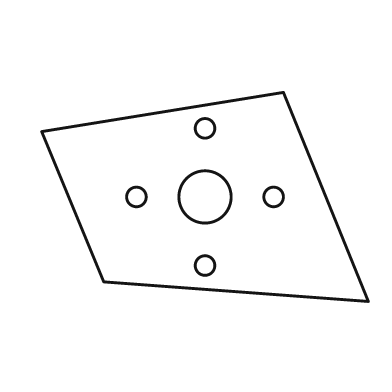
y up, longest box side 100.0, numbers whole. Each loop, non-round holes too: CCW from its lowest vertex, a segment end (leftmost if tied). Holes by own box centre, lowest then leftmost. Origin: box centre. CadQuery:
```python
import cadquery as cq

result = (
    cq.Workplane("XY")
    .moveTo(50.0, -32.0)
    .lineTo(24.0, 32.0)
    .lineTo(-50.0, 20.0)
    .lineTo(-31.0, -26.0)
    .close()
    .moveTo(0.0, -21.0)
    .circle(3.0)
    .moveTo(-21.0, 0.0)
    .circle(3.0)
    .moveTo(0.0, 0.0)
    .circle(8.0)
    .moveTo(21.0, 0.0)
    .circle(3.0)
    .moveTo(0.0, 21.0)
    .circle(3.0)
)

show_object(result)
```